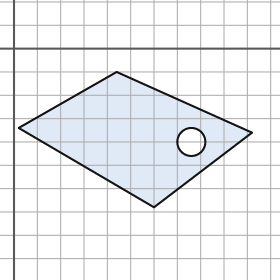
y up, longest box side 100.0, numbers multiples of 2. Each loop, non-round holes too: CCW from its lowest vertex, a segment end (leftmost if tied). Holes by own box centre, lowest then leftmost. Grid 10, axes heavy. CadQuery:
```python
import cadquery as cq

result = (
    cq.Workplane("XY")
    .moveTo(60.0, -68.0)
    .lineTo(102.0, -36.0)
    .lineTo(44.0, -10.0)
    .lineTo(2.0, -34.0)
    .close()
    .moveTo(76.0, -40.0)
    .circle(6.0)
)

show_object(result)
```